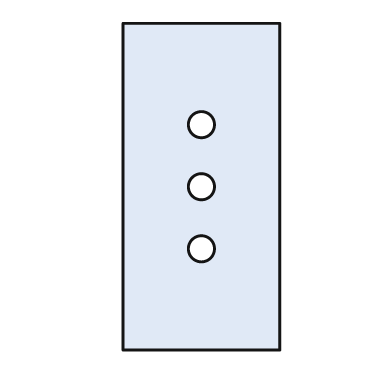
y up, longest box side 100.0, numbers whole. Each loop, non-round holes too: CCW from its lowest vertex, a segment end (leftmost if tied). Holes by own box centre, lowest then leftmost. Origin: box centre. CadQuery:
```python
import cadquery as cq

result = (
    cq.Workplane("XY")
    .moveTo(-24.0, -50.0)
    .lineTo(24.0, -50.0)
    .lineTo(24.0, 50.0)
    .lineTo(-24.0, 50.0)
    .close()
    .moveTo(0.0, -19.0)
    .circle(4.0)
    .moveTo(0.0, 0.0)
    .circle(4.0)
    .moveTo(0.0, 19.0)
    .circle(4.0)
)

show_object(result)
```